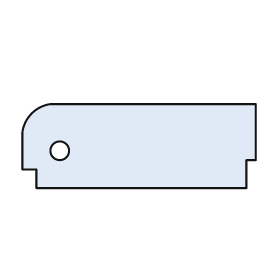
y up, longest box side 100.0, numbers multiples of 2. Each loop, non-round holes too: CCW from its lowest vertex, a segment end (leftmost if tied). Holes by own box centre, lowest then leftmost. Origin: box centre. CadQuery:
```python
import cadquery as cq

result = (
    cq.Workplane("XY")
    .moveTo(-44.0, -18.0)
    .lineTo(46.0, -18.0)
    .lineTo(46.0, -6.0)
    .lineTo(50.0, -6.0)
    .lineTo(50.0, 18.0)
    .lineTo(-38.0, 18.0)
    .threePointArc((-46.0, 14.0), (-50.0, 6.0))
    .lineTo(-50.0, -10.0)
    .lineTo(-44.0, -10.0)
    .close()
    .moveTo(-34.0, -2.0)
    .circle(4.0)
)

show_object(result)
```